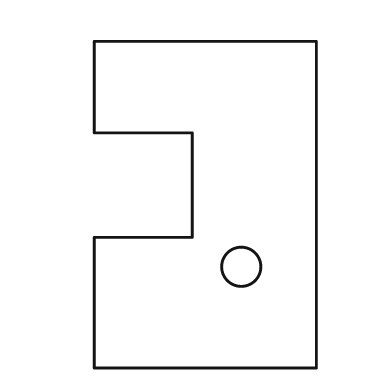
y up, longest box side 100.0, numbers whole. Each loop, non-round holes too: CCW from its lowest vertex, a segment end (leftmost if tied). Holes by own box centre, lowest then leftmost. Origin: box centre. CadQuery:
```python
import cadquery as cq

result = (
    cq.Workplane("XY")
    .moveTo(-34.0, -50.0)
    .lineTo(34.0, -50.0)
    .lineTo(34.0, 50.0)
    .lineTo(-34.0, 50.0)
    .lineTo(-34.0, 22.0)
    .lineTo(-4.0, 22.0)
    .lineTo(-4.0, -10.0)
    .lineTo(-34.0, -10.0)
    .close()
    .moveTo(11.0, -19.0)
    .circle(6.0)
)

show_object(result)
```